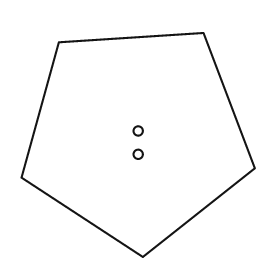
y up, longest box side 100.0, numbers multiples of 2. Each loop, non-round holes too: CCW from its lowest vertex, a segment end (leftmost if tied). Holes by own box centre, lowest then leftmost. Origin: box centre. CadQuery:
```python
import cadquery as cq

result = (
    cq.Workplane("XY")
    .moveTo(2.0, -48.0)
    .lineTo(50.0, -10.0)
    .lineTo(28.0, 48.0)
    .lineTo(-34.0, 44.0)
    .lineTo(-50.0, -14.0)
    .close()
    .moveTo(0.0, -4.0)
    .circle(2.0)
    .moveTo(0.0, 6.0)
    .circle(2.0)
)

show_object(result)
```